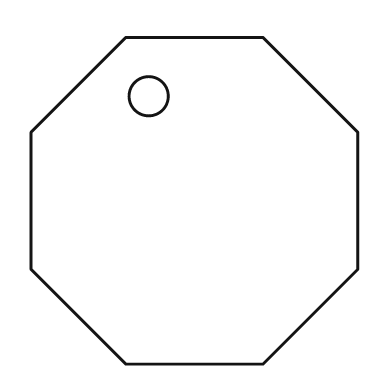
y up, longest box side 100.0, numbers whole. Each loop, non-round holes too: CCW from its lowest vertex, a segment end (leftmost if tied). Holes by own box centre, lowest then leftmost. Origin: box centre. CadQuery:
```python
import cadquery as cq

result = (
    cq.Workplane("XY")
    .moveTo(-21.0, -50.0)
    .lineTo(21.0, -50.0)
    .lineTo(50.0, -21.0)
    .lineTo(50.0, 21.0)
    .lineTo(21.0, 50.0)
    .lineTo(-21.0, 50.0)
    .lineTo(-50.0, 21.0)
    .lineTo(-50.0, -21.0)
    .close()
    .moveTo(-14.0, 32.0)
    .circle(6.0)
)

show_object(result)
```